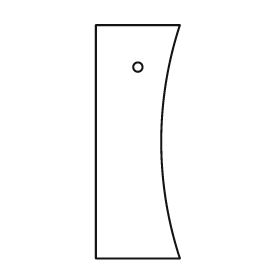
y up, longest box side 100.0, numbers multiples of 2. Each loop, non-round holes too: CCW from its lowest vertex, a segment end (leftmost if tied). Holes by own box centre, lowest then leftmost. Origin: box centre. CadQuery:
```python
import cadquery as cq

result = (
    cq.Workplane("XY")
    .moveTo(-18.0, -50.0)
    .lineTo(18.0, -50.0)
    .threePointArc((10.0, 0.0), (18.0, 50.0))
    .lineTo(-18.0, 50.0)
    .close()
    .moveTo(0.0, 32.0)
    .circle(2.0)
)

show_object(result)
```